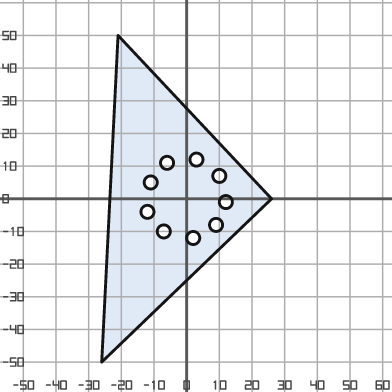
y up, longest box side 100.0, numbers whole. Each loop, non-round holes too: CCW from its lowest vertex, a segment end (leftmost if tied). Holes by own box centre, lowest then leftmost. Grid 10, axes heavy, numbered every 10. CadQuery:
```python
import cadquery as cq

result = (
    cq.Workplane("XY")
    .moveTo(-26.0, -50.0)
    .lineTo(26.0, 0.0)
    .lineTo(-21.0, 50.0)
    .close()
    .moveTo(2.0, -12.0)
    .circle(2.0)
    .moveTo(-7.0, -10.0)
    .circle(2.0)
    .moveTo(9.0, -8.0)
    .circle(2.0)
    .moveTo(-12.0, -4.0)
    .circle(2.0)
    .moveTo(12.0, -1.0)
    .circle(2.0)
    .moveTo(-11.0, 5.0)
    .circle(2.0)
    .moveTo(10.0, 7.0)
    .circle(2.0)
    .moveTo(-6.0, 11.0)
    .circle(2.0)
    .moveTo(3.0, 12.0)
    .circle(2.0)
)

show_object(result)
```